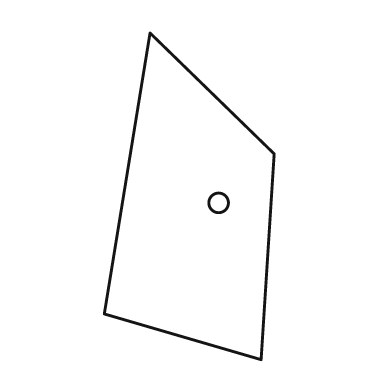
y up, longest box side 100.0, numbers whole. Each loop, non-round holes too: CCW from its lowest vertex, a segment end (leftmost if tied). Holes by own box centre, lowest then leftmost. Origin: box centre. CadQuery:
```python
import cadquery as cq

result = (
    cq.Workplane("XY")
    .moveTo(22.0, -50.0)
    .lineTo(26.0, 13.0)
    .lineTo(-12.0, 50.0)
    .lineTo(-26.0, -36.0)
    .close()
    .moveTo(9.0, -2.0)
    .circle(3.0)
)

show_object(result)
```